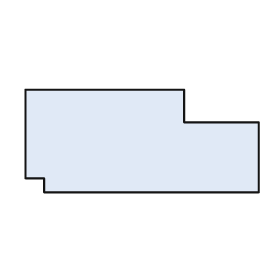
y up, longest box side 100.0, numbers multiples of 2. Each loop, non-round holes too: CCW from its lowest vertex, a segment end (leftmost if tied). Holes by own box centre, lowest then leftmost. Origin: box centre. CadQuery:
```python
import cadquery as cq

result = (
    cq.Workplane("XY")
    .moveTo(-42.0, -22.0)
    .lineTo(50.0, -22.0)
    .lineTo(50.0, 8.0)
    .lineTo(18.0, 8.0)
    .lineTo(18.0, 22.0)
    .lineTo(-50.0, 22.0)
    .lineTo(-50.0, -16.0)
    .lineTo(-42.0, -16.0)
    .close()
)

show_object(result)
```